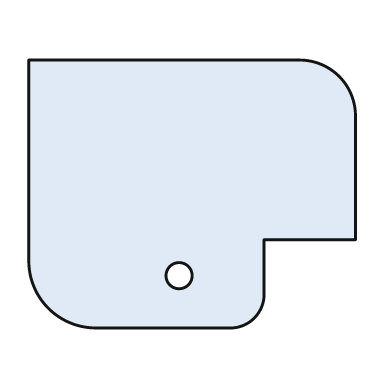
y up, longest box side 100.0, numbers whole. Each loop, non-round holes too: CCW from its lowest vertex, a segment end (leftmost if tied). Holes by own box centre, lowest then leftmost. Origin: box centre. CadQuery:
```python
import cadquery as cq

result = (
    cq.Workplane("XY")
    .moveTo(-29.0, -41.0)
    .lineTo(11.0, -41.0)
    .threePointArc((19.0, -38.0), (22.0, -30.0))
    .lineTo(22.0, -14.0)
    .lineTo(50.0, -14.0)
    .lineTo(50.0, 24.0)
    .threePointArc((45.0, 36.0), (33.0, 41.0))
    .lineTo(-50.0, 41.0)
    .lineTo(-50.0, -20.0)
    .threePointArc((-44.0, -35.0), (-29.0, -41.0))
    .close()
    .moveTo(-4.0, -25.0)
    .circle(4.0)
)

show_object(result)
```